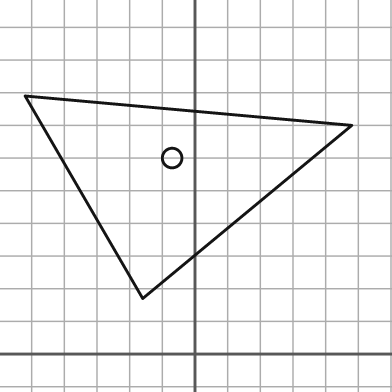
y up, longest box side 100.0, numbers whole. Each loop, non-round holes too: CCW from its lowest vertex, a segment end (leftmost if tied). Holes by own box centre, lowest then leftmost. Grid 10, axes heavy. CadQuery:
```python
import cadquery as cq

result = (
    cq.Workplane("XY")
    .moveTo(-16.0, 17.0)
    .lineTo(48.0, 70.0)
    .lineTo(-52.0, 79.0)
    .close()
    .moveTo(-7.0, 60.0)
    .circle(3.0)
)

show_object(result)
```